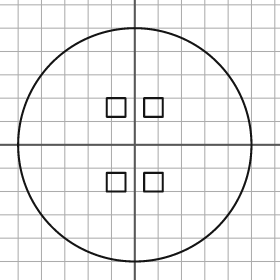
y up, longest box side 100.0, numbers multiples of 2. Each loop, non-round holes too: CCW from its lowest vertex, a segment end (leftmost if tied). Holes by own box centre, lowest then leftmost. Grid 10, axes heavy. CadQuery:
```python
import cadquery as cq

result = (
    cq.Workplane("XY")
    .moveTo(0.0, 0.0)
    .circle(50.0)
    .moveTo(-12.0, -20.0)
    .lineTo(-4.0, -20.0)
    .lineTo(-4.0, -12.0)
    .lineTo(-12.0, -12.0)
    .close()
    .moveTo(4.0, -20.0)
    .lineTo(12.0, -20.0)
    .lineTo(12.0, -12.0)
    .lineTo(4.0, -12.0)
    .close()
    .moveTo(-12.0, 12.0)
    .lineTo(-4.0, 12.0)
    .lineTo(-4.0, 20.0)
    .lineTo(-12.0, 20.0)
    .close()
    .moveTo(4.0, 12.0)
    .lineTo(12.0, 12.0)
    .lineTo(12.0, 20.0)
    .lineTo(4.0, 20.0)
    .close()
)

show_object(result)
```